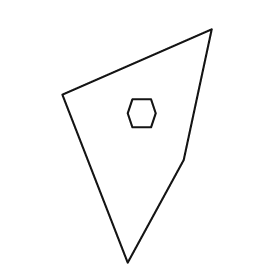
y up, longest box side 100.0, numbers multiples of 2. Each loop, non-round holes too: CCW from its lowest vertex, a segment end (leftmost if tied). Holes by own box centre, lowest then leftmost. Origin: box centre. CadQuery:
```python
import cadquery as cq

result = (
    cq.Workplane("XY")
    .moveTo(-4.0, -50.0)
    .lineTo(20.0, -6.0)
    .lineTo(32.0, 50.0)
    .lineTo(-32.0, 22.0)
    .close()
    .moveTo(-2.0, 8.0)
    .lineTo(6.0, 8.0)
    .lineTo(8.0, 14.0)
    .lineTo(6.0, 20.0)
    .lineTo(-2.0, 20.0)
    .lineTo(-4.0, 14.0)
    .close()
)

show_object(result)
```